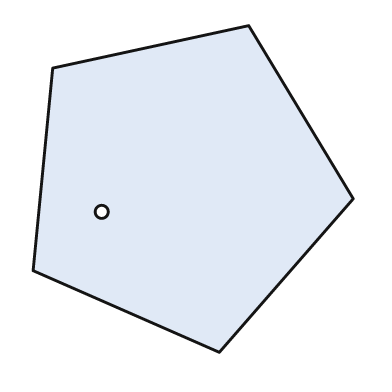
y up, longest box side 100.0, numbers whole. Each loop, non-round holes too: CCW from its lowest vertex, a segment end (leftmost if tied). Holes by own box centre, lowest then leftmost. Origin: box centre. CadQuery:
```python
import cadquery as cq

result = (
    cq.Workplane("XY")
    .moveTo(8.0, -50.0)
    .lineTo(49.0, -3.0)
    .lineTo(17.0, 50.0)
    .lineTo(-43.0, 37.0)
    .lineTo(-49.0, -25.0)
    .close()
    .moveTo(-28.0, -7.0)
    .circle(2.0)
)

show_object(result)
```